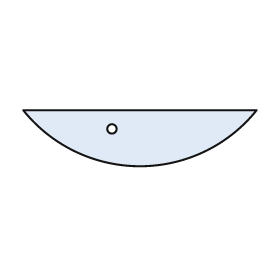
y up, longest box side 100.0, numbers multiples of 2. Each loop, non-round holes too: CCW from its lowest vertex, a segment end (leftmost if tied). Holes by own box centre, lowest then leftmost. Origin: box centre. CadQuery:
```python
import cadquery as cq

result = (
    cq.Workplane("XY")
    .moveTo(-50.0, 12.0)
    .threePointArc((0.0, -12.0), (50.0, 12.0))
    .close()
    .moveTo(-12.0, 4.0)
    .circle(2.0)
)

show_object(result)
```